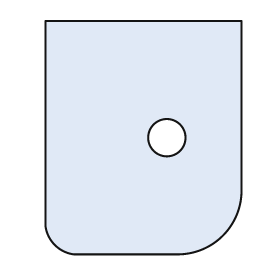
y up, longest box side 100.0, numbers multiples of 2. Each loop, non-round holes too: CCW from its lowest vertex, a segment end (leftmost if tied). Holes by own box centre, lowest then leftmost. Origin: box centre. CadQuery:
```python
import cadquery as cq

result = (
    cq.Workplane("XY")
    .moveTo(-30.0, -50.0)
    .lineTo(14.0, -50.0)
    .threePointArc((34.0, -42.0), (42.0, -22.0))
    .lineTo(42.0, 50.0)
    .lineTo(-42.0, 50.0)
    .lineTo(-42.0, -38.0)
    .threePointArc((-38.0, -46.0), (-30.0, -50.0))
    .close()
    .moveTo(10.0, 0.0)
    .circle(8.0)
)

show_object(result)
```